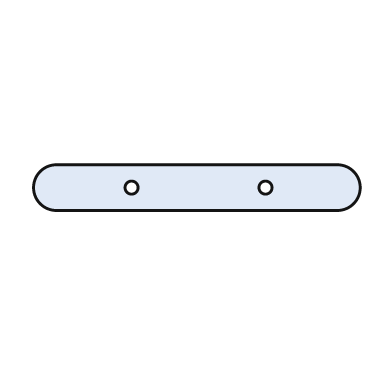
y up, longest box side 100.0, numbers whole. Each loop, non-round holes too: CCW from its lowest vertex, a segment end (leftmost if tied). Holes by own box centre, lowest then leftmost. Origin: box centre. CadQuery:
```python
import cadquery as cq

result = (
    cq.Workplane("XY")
    .moveTo(-43.0, -7.0)
    .lineTo(43.0, -7.0)
    .threePointArc((50.0, 0.0), (43.0, 7.0))
    .lineTo(-43.0, 7.0)
    .threePointArc((-50.0, 0.0), (-43.0, -7.0))
    .close()
    .moveTo(-20.0, 0.0)
    .circle(2.0)
    .moveTo(21.0, 0.0)
    .circle(2.0)
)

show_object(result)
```